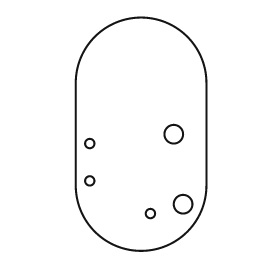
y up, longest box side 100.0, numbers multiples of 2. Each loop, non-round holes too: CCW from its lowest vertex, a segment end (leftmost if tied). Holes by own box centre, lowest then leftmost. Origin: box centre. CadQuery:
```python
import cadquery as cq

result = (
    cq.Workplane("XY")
    .moveTo(-28.0, -22.0)
    .threePointArc((0.0, -50.0), (28.0, -22.0))
    .lineTo(28.0, 22.0)
    .threePointArc((0.0, 50.0), (-28.0, 22.0))
    .close()
    .moveTo(4.0, -34.0)
    .circle(2.0)
    .moveTo(18.0, -30.0)
    .circle(4.0)
    .moveTo(-22.0, -20.0)
    .circle(2.0)
    .moveTo(-22.0, -4.0)
    .circle(2.0)
    .moveTo(14.0, 0.0)
    .circle(4.0)
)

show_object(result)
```